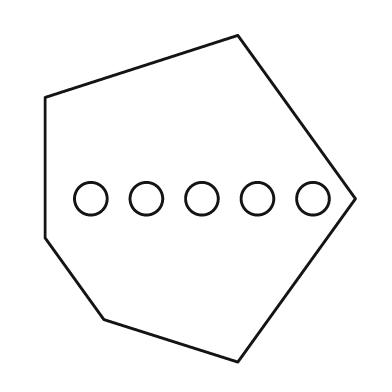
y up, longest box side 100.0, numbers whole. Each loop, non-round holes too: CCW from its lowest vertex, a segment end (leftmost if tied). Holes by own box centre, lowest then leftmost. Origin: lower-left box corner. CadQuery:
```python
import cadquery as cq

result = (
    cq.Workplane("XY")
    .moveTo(59.0, 0.0)
    .lineTo(95.0, 50.0)
    .lineTo(59.0, 100.0)
    .lineTo(0.0, 81.0)
    .lineTo(0.0, 38.0)
    .lineTo(18.0, 13.0)
    .close()
    .moveTo(14.0, 50.0)
    .circle(5.0)
    .moveTo(31.0, 50.0)
    .circle(5.0)
    .moveTo(48.0, 50.0)
    .circle(5.0)
    .moveTo(65.0, 50.0)
    .circle(5.0)
    .moveTo(82.0, 50.0)
    .circle(5.0)
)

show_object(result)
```